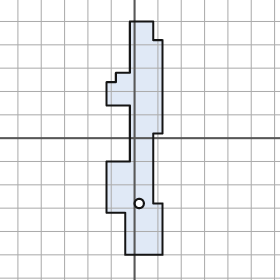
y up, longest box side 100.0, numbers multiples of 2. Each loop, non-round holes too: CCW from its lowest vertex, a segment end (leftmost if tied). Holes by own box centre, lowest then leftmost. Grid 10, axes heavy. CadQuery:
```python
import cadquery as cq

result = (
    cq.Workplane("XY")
    .moveTo(-4.0, -50.0)
    .lineTo(12.0, -50.0)
    .lineTo(12.0, -28.0)
    .lineTo(8.0, -28.0)
    .lineTo(8.0, 2.0)
    .lineTo(12.0, 2.0)
    .lineTo(12.0, 42.0)
    .lineTo(8.0, 42.0)
    .lineTo(8.0, 50.0)
    .lineTo(-2.0, 50.0)
    .lineTo(-2.0, 28.0)
    .lineTo(-8.0, 28.0)
    .lineTo(-8.0, 24.0)
    .lineTo(-12.0, 24.0)
    .lineTo(-12.0, 14.0)
    .lineTo(-2.0, 14.0)
    .lineTo(-2.0, -10.0)
    .lineTo(-12.0, -10.0)
    .lineTo(-12.0, -32.0)
    .lineTo(-4.0, -32.0)
    .close()
    .moveTo(2.0, -28.0)
    .circle(2.0)
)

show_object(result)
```